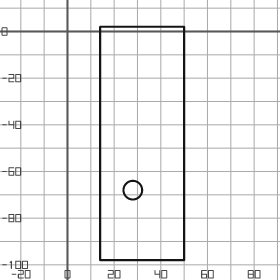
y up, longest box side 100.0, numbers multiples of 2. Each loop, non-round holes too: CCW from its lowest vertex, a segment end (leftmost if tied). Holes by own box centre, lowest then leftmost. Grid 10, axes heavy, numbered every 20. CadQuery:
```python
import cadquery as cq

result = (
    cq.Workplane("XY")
    .moveTo(14.0, -98.0)
    .lineTo(50.0, -98.0)
    .lineTo(50.0, 2.0)
    .lineTo(14.0, 2.0)
    .close()
    .moveTo(28.0, -68.0)
    .circle(4.0)
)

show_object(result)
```